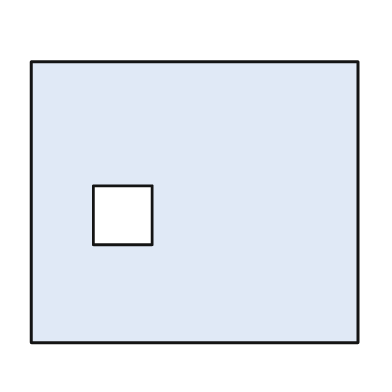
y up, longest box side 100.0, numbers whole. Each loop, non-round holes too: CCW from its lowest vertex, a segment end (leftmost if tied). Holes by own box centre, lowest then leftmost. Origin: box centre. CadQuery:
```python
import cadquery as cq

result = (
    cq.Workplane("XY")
    .moveTo(-50.0, -43.0)
    .lineTo(50.0, -43.0)
    .lineTo(50.0, 43.0)
    .lineTo(-50.0, 43.0)
    .close()
    .moveTo(-31.0, -13.0)
    .lineTo(-13.0, -13.0)
    .lineTo(-13.0, 5.0)
    .lineTo(-31.0, 5.0)
    .close()
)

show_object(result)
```